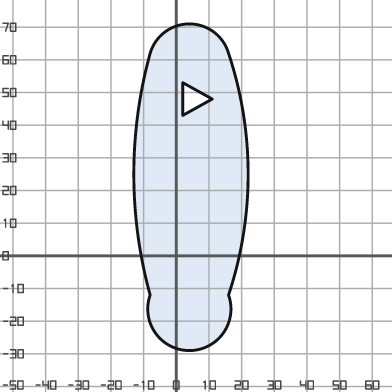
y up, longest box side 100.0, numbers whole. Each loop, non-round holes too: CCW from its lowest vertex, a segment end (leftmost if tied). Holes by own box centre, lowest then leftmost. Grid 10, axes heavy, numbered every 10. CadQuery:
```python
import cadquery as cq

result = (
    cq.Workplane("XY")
    .moveTo(-8.0, -12.0)
    .threePointArc((4.0, -29.0), (16.0, -12.0))
    .threePointArc((22.0, 25.0), (16.0, 62.0))
    .threePointArc((4.0, 71.0), (-8.0, 62.0))
    .threePointArc((-13.0, 25.0), (-8.0, -12.0))
    .close()
    .moveTo(2.0, 43.0)
    .lineTo(11.0, 48.0)
    .lineTo(2.0, 53.0)
    .close()
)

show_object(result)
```